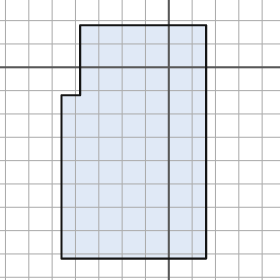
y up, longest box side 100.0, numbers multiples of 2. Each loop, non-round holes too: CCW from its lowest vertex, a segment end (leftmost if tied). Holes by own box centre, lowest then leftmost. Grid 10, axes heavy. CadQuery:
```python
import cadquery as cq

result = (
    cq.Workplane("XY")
    .moveTo(-46.0, -82.0)
    .lineTo(16.0, -82.0)
    .lineTo(16.0, 18.0)
    .lineTo(-38.0, 18.0)
    .lineTo(-38.0, -12.0)
    .lineTo(-46.0, -12.0)
    .close()
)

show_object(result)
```